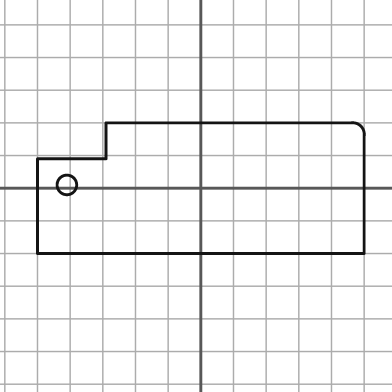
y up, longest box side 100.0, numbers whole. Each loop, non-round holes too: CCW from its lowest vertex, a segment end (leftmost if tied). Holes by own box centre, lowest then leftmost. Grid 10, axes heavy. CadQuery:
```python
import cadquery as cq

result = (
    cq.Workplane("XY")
    .moveTo(-50.0, -20.0)
    .lineTo(50.0, -20.0)
    .lineTo(50.0, 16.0)
    .threePointArc((49.0, 19.0), (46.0, 20.0))
    .lineTo(-29.0, 20.0)
    .lineTo(-29.0, 9.0)
    .lineTo(-50.0, 9.0)
    .close()
    .moveTo(-41.0, 1.0)
    .circle(3.0)
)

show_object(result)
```